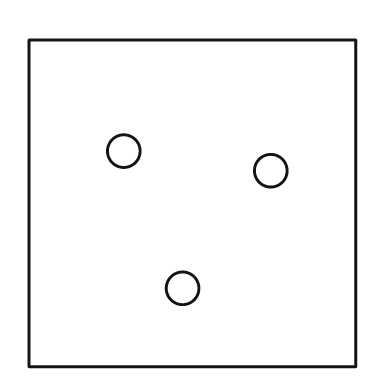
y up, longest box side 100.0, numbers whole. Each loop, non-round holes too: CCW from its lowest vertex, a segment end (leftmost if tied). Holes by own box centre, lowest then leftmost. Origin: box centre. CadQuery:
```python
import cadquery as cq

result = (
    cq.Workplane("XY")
    .moveTo(-50.0, -50.0)
    .lineTo(50.0, -50.0)
    .lineTo(50.0, 50.0)
    .lineTo(-50.0, 50.0)
    .close()
    .moveTo(-3.0, -26.0)
    .circle(5.0)
    .moveTo(24.0, 10.0)
    .circle(5.0)
    .moveTo(-21.0, 16.0)
    .circle(5.0)
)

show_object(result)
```